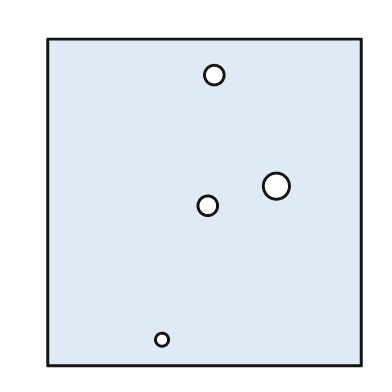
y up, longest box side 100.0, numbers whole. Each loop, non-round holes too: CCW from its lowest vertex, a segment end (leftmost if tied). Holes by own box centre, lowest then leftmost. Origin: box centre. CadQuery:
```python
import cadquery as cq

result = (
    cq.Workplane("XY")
    .moveTo(-48.0, -50.0)
    .lineTo(48.0, -50.0)
    .lineTo(48.0, 50.0)
    .lineTo(-48.0, 50.0)
    .close()
    .moveTo(-13.0, -42.0)
    .circle(2.0)
    .moveTo(1.0, -1.0)
    .circle(3.0)
    .moveTo(22.0, 5.0)
    .circle(4.0)
    .moveTo(3.0, 39.0)
    .circle(3.0)
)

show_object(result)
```